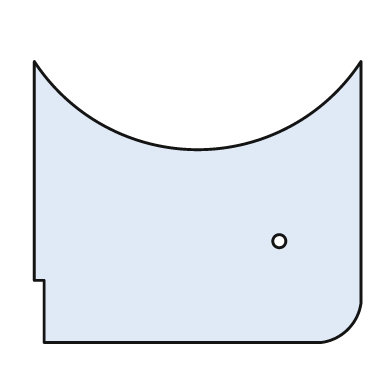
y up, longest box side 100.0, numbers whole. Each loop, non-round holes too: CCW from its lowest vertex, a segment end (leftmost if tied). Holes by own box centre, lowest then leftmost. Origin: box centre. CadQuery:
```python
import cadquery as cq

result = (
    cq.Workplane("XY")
    .moveTo(-47.0, -43.0)
    .lineTo(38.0, -43.0)
    .threePointArc((46.0, -39.0), (50.0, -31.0))
    .lineTo(50.0, 43.0)
    .threePointArc((0.0, 16.0), (-50.0, 43.0))
    .lineTo(-50.0, -24.0)
    .lineTo(-47.0, -24.0)
    .close()
    .moveTo(25.0, -12.0)
    .circle(2.0)
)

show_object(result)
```